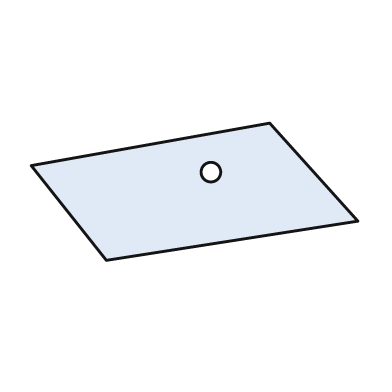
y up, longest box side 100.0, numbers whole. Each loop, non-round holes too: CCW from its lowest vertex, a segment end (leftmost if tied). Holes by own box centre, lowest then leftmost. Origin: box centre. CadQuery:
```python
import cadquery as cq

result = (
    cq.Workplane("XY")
    .moveTo(-27.0, -21.0)
    .lineTo(50.0, -9.0)
    .lineTo(23.0, 21.0)
    .lineTo(-50.0, 8.0)
    .close()
    .moveTo(5.0, 6.0)
    .circle(3.0)
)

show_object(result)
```